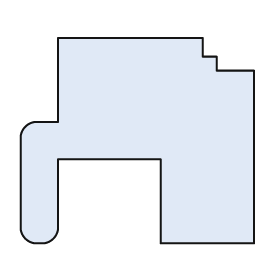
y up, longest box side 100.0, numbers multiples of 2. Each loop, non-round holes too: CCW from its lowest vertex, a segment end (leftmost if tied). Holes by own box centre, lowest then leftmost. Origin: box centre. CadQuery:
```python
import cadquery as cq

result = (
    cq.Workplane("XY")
    .moveTo(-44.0, -44.0)
    .lineTo(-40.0, -44.0)
    .threePointArc((-36.0, -42.0), (-34.0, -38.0))
    .lineTo(-34.0, -8.0)
    .lineTo(10.0, -8.0)
    .lineTo(10.0, -44.0)
    .lineTo(50.0, -44.0)
    .lineTo(50.0, 30.0)
    .lineTo(34.0, 30.0)
    .lineTo(34.0, 36.0)
    .lineTo(28.0, 36.0)
    .lineTo(28.0, 44.0)
    .lineTo(-34.0, 44.0)
    .lineTo(-34.0, 8.0)
    .lineTo(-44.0, 8.0)
    .threePointArc((-48.0, 6.0), (-50.0, 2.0))
    .lineTo(-50.0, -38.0)
    .threePointArc((-48.0, -42.0), (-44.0, -44.0))
    .close()
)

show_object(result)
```